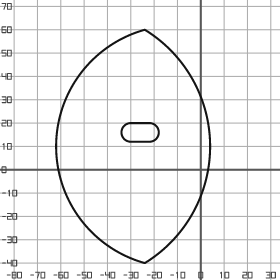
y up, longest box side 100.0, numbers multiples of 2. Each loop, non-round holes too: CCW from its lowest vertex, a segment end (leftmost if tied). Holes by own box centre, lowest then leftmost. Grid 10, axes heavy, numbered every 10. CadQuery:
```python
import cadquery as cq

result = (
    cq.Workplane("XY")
    .moveTo(-24.0, -40.0)
    .threePointArc((4.0, 10.0), (-24.0, 60.0))
    .threePointArc((-62.0, 10.0), (-24.0, -40.0))
    .close()
    .moveTo(-30.0, 12.0)
    .lineTo(-22.0, 12.0)
    .threePointArc((-18.0, 16.0), (-22.0, 20.0))
    .lineTo(-30.0, 20.0)
    .threePointArc((-34.0, 16.0), (-30.0, 12.0))
    .close()
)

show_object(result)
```